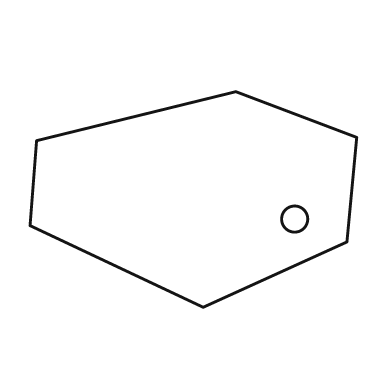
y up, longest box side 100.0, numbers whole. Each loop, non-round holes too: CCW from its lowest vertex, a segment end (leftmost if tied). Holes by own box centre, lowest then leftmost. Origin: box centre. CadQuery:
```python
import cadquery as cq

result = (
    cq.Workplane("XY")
    .moveTo(3.0, -33.0)
    .lineTo(47.0, -13.0)
    .lineTo(50.0, 19.0)
    .lineTo(13.0, 33.0)
    .lineTo(-48.0, 18.0)
    .lineTo(-50.0, -8.0)
    .close()
    .moveTo(31.0, -6.0)
    .circle(4.0)
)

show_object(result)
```